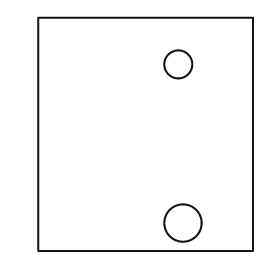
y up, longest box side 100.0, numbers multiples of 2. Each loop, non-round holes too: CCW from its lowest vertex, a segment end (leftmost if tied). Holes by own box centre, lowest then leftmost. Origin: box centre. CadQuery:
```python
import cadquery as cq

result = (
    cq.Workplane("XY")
    .moveTo(-46.0, -50.0)
    .lineTo(46.0, -50.0)
    .lineTo(46.0, 50.0)
    .lineTo(-46.0, 50.0)
    .close()
    .moveTo(16.0, -38.0)
    .circle(8.0)
    .moveTo(14.0, 30.0)
    .circle(6.0)
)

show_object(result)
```